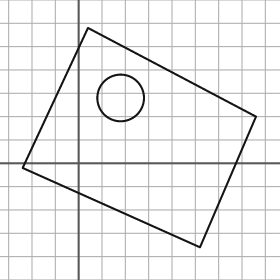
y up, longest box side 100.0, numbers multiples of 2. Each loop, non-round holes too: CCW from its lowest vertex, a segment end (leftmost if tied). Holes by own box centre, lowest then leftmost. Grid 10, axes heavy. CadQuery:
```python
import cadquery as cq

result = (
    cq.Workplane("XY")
    .moveTo(52.0, -36.0)
    .lineTo(76.0, 20.0)
    .lineTo(4.0, 58.0)
    .lineTo(-24.0, -2.0)
    .close()
    .moveTo(18.0, 28.0)
    .circle(10.0)
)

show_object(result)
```